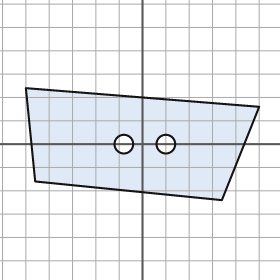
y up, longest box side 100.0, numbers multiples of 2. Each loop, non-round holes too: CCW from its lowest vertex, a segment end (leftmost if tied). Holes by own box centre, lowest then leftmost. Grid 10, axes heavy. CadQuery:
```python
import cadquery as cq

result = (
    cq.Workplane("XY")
    .moveTo(34.0, -24.0)
    .lineTo(50.0, 16.0)
    .lineTo(-50.0, 24.0)
    .lineTo(-46.0, -16.0)
    .close()
    .moveTo(-8.0, 0.0)
    .circle(4.0)
    .moveTo(10.0, 0.0)
    .circle(4.0)
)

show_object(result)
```